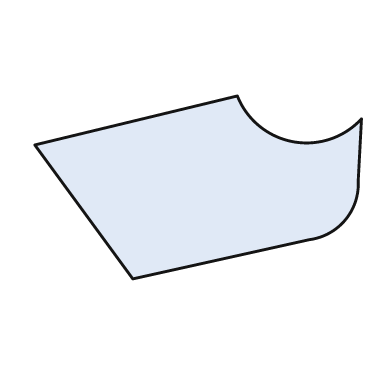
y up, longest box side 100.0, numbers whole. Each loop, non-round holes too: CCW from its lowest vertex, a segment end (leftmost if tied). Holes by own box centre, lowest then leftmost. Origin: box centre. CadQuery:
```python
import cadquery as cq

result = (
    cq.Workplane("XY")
    .moveTo(-20.0, -28.0)
    .lineTo(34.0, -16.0)
    .threePointArc((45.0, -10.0), (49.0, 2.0))
    .lineTo(50.0, 21.0)
    .threePointArc((29.0, 14.0), (12.0, 28.0))
    .lineTo(-50.0, 13.0)
    .close()
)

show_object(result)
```